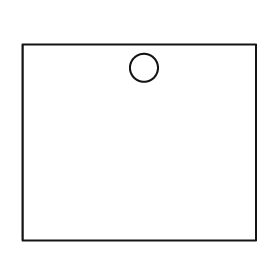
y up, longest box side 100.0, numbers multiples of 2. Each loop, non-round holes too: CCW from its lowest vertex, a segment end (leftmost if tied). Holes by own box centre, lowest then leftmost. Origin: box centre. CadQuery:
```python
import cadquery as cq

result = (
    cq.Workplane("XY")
    .moveTo(-50.0, -42.0)
    .lineTo(50.0, -42.0)
    .lineTo(50.0, 42.0)
    .lineTo(-50.0, 42.0)
    .close()
    .moveTo(2.0, 32.0)
    .circle(6.0)
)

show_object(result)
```